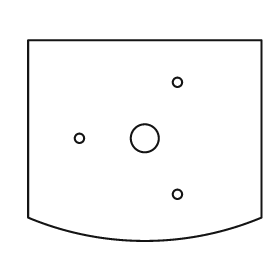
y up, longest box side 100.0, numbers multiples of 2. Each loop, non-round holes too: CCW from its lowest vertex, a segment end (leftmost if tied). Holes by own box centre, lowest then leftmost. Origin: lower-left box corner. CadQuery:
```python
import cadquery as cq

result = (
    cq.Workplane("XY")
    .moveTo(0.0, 10.0)
    .threePointArc((50.0, 0.0), (100.0, 10.0))
    .lineTo(100.0, 86.0)
    .lineTo(0.0, 86.0)
    .close()
    .moveTo(64.0, 20.0)
    .circle(2.0)
    .moveTo(22.0, 44.0)
    .circle(2.0)
    .moveTo(50.0, 44.0)
    .circle(6.0)
    .moveTo(64.0, 68.0)
    .circle(2.0)
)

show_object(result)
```